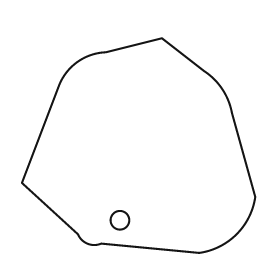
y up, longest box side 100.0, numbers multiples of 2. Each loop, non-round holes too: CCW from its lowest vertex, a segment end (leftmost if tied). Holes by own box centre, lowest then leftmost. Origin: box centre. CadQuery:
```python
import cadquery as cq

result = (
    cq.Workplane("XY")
    .moveTo(26.0, -46.0)
    .threePointArc((42.0, -38.0), (50.0, -22.0))
    .lineTo(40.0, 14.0)
    .threePointArc((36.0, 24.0), (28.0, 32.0))
    .lineTo(10.0, 46.0)
    .lineTo(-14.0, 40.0)
    .threePointArc((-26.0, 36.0), (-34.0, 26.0))
    .lineTo(-50.0, -16.0)
    .lineTo(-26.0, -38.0)
    .threePointArc((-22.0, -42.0), (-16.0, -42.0))
    .close()
    .moveTo(-8.0, -32.0)
    .circle(4.0)
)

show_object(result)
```